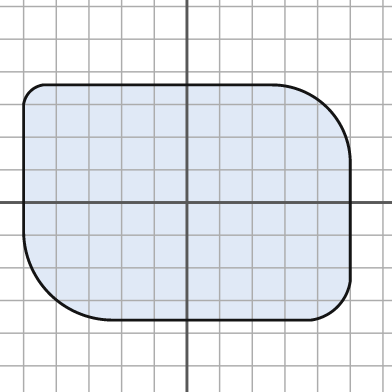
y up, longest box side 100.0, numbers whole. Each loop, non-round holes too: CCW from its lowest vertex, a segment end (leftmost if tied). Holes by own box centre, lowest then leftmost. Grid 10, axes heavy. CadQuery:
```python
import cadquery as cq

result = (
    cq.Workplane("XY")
    .moveTo(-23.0, -36.0)
    .lineTo(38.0, -36.0)
    .threePointArc((46.0, -32.0), (50.0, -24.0))
    .lineTo(50.0, 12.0)
    .threePointArc((43.0, 29.0), (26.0, 36.0))
    .lineTo(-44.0, 36.0)
    .threePointArc((-48.0, 34.0), (-50.0, 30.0))
    .lineTo(-50.0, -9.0)
    .threePointArc((-42.0, -28.0), (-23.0, -36.0))
    .close()
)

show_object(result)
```